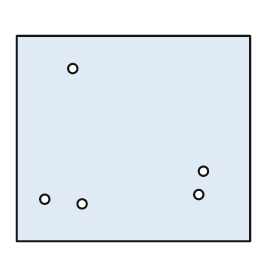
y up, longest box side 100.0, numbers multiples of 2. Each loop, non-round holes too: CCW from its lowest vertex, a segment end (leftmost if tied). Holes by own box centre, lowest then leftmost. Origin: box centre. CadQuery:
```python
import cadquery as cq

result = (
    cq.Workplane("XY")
    .moveTo(-50.0, -44.0)
    .lineTo(50.0, -44.0)
    .lineTo(50.0, 44.0)
    .lineTo(-50.0, 44.0)
    .close()
    .moveTo(-22.0, -28.0)
    .circle(2.0)
    .moveTo(-38.0, -26.0)
    .circle(2.0)
    .moveTo(28.0, -24.0)
    .circle(2.0)
    .moveTo(30.0, -14.0)
    .circle(2.0)
    .moveTo(-26.0, 30.0)
    .circle(2.0)
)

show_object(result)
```